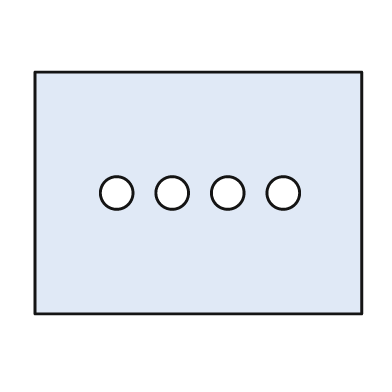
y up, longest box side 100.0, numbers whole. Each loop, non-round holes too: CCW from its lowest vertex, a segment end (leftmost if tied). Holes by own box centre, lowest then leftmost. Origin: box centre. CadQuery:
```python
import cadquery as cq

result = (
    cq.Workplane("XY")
    .moveTo(-50.0, -37.0)
    .lineTo(50.0, -37.0)
    .lineTo(50.0, 37.0)
    .lineTo(-50.0, 37.0)
    .close()
    .moveTo(-25.0, 0.0)
    .circle(5.0)
    .moveTo(-8.0, 0.0)
    .circle(5.0)
    .moveTo(9.0, 0.0)
    .circle(5.0)
    .moveTo(26.0, 0.0)
    .circle(5.0)
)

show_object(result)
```